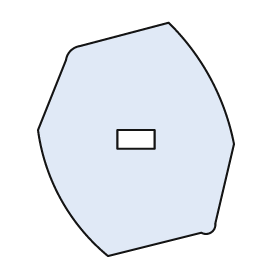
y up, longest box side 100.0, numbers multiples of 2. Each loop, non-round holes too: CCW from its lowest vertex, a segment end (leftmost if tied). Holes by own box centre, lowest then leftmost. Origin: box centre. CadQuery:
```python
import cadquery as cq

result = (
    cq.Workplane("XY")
    .moveTo(-12.0, -50.0)
    .lineTo(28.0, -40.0)
    .threePointArc((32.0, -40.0), (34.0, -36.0))
    .lineTo(42.0, -2.0)
    .threePointArc((32.0, 26.0), (14.0, 50.0))
    .lineTo(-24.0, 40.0)
    .threePointArc((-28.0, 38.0), (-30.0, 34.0))
    .lineTo(-42.0, 4.0)
    .threePointArc((-32.0, -26.0), (-12.0, -50.0))
    .close()
    .moveTo(-8.0, -4.0)
    .lineTo(8.0, -4.0)
    .lineTo(8.0, 4.0)
    .lineTo(-8.0, 4.0)
    .close()
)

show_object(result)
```